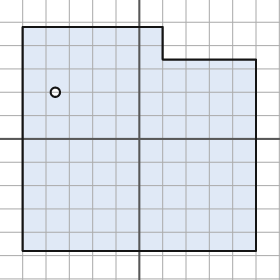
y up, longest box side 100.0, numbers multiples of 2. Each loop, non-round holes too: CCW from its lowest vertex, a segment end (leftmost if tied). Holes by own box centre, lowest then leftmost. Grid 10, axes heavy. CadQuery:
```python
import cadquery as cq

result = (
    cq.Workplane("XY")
    .moveTo(-50.0, -48.0)
    .lineTo(50.0, -48.0)
    .lineTo(50.0, 34.0)
    .lineTo(10.0, 34.0)
    .lineTo(10.0, 48.0)
    .lineTo(-50.0, 48.0)
    .close()
    .moveTo(-36.0, 20.0)
    .circle(2.0)
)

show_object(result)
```